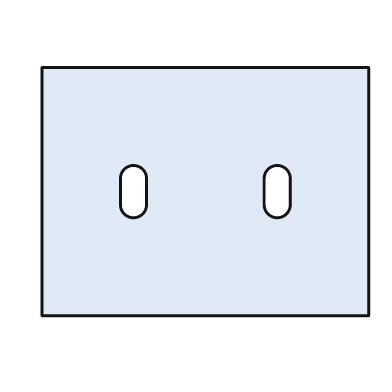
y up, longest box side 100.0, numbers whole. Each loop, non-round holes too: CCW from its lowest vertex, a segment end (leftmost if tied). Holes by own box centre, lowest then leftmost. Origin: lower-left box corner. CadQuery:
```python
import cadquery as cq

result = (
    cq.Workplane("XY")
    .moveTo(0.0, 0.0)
    .lineTo(100.0, 0.0)
    .lineTo(100.0, 76.0)
    .lineTo(0.0, 76.0)
    .close()
    .moveTo(24.0, 34.0)
    .threePointArc((28.0, 30.0), (32.0, 34.0))
    .lineTo(32.0, 42.0)
    .threePointArc((28.0, 46.0), (24.0, 42.0))
    .close()
    .moveTo(68.0, 34.0)
    .threePointArc((72.0, 30.0), (76.0, 34.0))
    .lineTo(76.0, 42.0)
    .threePointArc((72.0, 46.0), (68.0, 42.0))
    .close()
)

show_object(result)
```